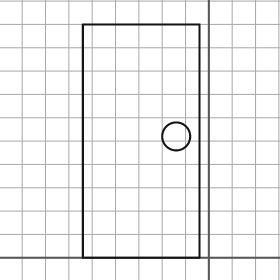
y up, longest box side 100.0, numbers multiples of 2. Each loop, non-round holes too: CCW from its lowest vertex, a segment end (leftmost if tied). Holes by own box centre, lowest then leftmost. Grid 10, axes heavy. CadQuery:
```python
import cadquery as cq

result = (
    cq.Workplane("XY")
    .moveTo(-54.0, 0.0)
    .lineTo(-4.0, 0.0)
    .lineTo(-4.0, 100.0)
    .lineTo(-54.0, 100.0)
    .close()
    .moveTo(-14.0, 52.0)
    .circle(6.0)
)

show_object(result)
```